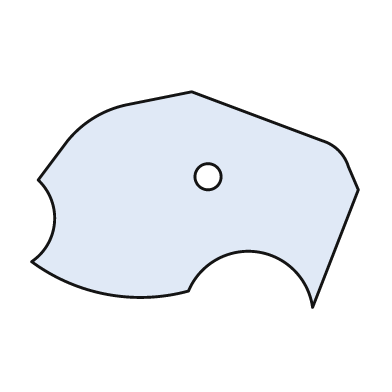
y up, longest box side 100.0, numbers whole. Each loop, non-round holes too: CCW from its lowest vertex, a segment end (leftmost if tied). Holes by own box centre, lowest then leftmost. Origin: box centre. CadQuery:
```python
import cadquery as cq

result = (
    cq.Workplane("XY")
    .moveTo(36.0, -33.0)
    .lineTo(50.0, 3.0)
    .lineTo(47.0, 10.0)
    .threePointArc((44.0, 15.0), (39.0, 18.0))
    .lineTo(-1.0, 33.0)
    .lineTo(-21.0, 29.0)
    .threePointArc((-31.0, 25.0), (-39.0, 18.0))
    .lineTo(-48.0, 6.0)
    .threePointArc((-43.0, -7.0), (-50.0, -19.0))
    .threePointArc((-27.0, -29.0), (-2.0, -28.0))
    .threePointArc((19.0, -16.0), (36.0, -33.0))
    .close()
    .moveTo(4.0, 7.0)
    .circle(4.0)
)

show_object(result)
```